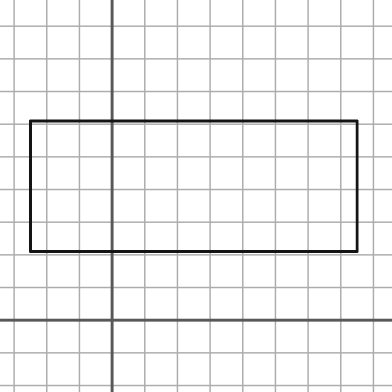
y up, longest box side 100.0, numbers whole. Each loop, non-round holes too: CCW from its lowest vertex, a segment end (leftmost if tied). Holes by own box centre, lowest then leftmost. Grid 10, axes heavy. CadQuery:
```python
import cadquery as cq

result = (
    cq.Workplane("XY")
    .moveTo(-25.0, 21.0)
    .lineTo(75.0, 21.0)
    .lineTo(75.0, 61.0)
    .lineTo(-25.0, 61.0)
    .close()
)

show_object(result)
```